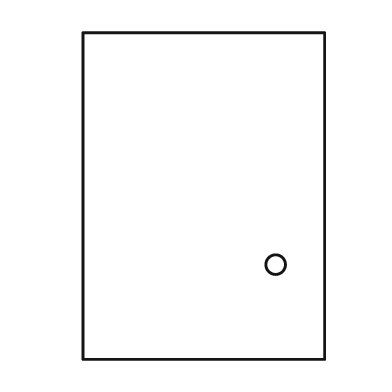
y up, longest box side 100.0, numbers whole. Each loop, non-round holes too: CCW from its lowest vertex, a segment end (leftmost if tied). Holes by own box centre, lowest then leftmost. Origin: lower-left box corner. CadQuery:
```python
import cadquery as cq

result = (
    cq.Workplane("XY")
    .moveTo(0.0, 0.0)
    .lineTo(74.0, 0.0)
    .lineTo(74.0, 100.0)
    .lineTo(0.0, 100.0)
    .close()
    .moveTo(59.0, 29.0)
    .circle(3.0)
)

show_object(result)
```